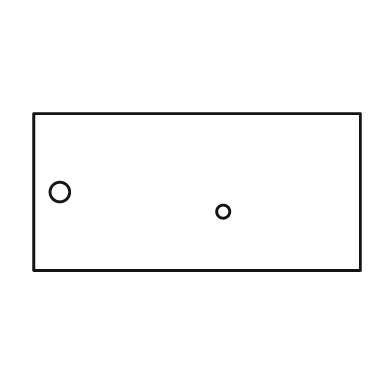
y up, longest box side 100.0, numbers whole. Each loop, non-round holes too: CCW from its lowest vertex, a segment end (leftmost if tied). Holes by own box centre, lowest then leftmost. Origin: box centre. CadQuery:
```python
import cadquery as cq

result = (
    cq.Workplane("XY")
    .moveTo(-50.0, -24.0)
    .lineTo(50.0, -24.0)
    .lineTo(50.0, 24.0)
    .lineTo(-50.0, 24.0)
    .close()
    .moveTo(8.0, -6.0)
    .circle(2.0)
    .moveTo(-42.0, 0.0)
    .circle(3.0)
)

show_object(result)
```